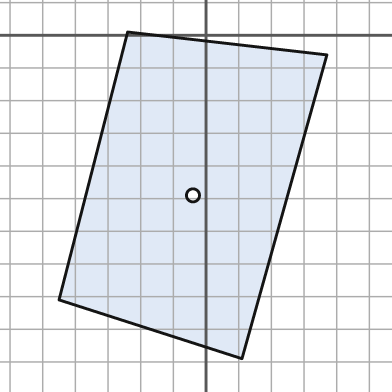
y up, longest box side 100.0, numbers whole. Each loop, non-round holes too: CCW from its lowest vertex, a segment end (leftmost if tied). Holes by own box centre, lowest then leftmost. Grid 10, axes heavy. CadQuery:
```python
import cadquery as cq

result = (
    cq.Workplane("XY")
    .moveTo(11.0, -99.0)
    .lineTo(37.0, -6.0)
    .lineTo(-24.0, 1.0)
    .lineTo(-45.0, -81.0)
    .close()
    .moveTo(-4.0, -49.0)
    .circle(2.0)
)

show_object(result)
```